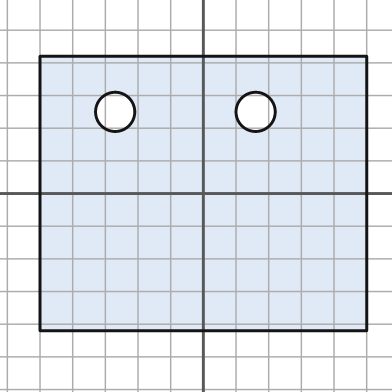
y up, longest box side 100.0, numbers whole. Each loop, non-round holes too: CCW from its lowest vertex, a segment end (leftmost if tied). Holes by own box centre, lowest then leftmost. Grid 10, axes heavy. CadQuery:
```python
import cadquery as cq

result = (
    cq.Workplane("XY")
    .moveTo(-50.0, -42.0)
    .lineTo(50.0, -42.0)
    .lineTo(50.0, 42.0)
    .lineTo(-50.0, 42.0)
    .close()
    .moveTo(-27.0, 25.0)
    .circle(6.0)
    .moveTo(16.0, 25.0)
    .circle(6.0)
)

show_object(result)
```